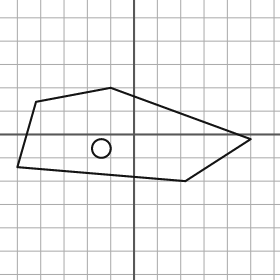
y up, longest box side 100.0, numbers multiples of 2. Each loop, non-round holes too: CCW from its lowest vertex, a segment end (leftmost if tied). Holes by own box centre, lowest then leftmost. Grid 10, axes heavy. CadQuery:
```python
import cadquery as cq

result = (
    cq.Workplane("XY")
    .moveTo(22.0, -20.0)
    .lineTo(50.0, -2.0)
    .lineTo(-10.0, 20.0)
    .lineTo(-42.0, 14.0)
    .lineTo(-50.0, -14.0)
    .close()
    .moveTo(-14.0, -6.0)
    .circle(4.0)
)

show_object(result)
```